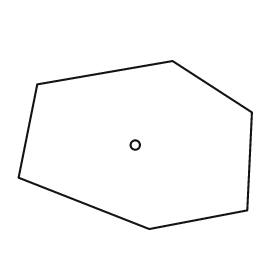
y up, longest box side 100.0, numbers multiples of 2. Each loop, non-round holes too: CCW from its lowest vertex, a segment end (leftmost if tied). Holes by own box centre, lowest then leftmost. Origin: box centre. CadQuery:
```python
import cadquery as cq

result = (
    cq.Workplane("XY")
    .moveTo(6.0, -36.0)
    .lineTo(48.0, -28.0)
    .lineTo(50.0, 14.0)
    .lineTo(16.0, 36.0)
    .lineTo(-42.0, 26.0)
    .lineTo(-50.0, -14.0)
    .close()
    .moveTo(0.0, 0.0)
    .circle(2.0)
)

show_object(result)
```